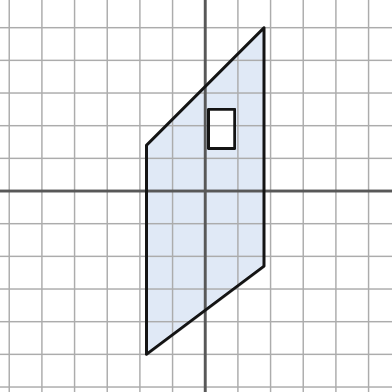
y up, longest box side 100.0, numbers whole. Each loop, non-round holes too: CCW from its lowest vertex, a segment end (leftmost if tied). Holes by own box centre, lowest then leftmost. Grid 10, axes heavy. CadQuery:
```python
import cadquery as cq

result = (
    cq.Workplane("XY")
    .moveTo(-18.0, -50.0)
    .lineTo(18.0, -23.0)
    .lineTo(18.0, 50.0)
    .lineTo(-18.0, 14.0)
    .close()
    .moveTo(1.0, 13.0)
    .lineTo(9.0, 13.0)
    .lineTo(9.0, 25.0)
    .lineTo(1.0, 25.0)
    .close()
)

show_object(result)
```